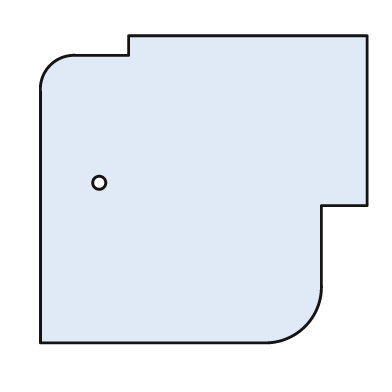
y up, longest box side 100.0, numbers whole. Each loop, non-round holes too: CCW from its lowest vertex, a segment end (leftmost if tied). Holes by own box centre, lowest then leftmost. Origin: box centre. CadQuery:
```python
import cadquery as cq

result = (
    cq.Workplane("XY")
    .moveTo(-50.0, -47.0)
    .lineTo(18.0, -47.0)
    .threePointArc((31.0, -42.0), (36.0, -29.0))
    .lineTo(36.0, -5.0)
    .lineTo(50.0, -5.0)
    .lineTo(50.0, 47.0)
    .lineTo(-23.0, 47.0)
    .lineTo(-23.0, 41.0)
    .lineTo(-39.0, 41.0)
    .threePointArc((-47.0, 38.0), (-50.0, 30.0))
    .close()
    .moveTo(-32.0, 2.0)
    .circle(2.0)
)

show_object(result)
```